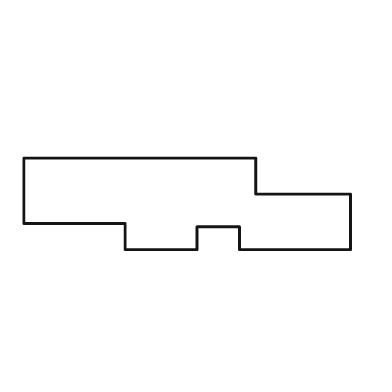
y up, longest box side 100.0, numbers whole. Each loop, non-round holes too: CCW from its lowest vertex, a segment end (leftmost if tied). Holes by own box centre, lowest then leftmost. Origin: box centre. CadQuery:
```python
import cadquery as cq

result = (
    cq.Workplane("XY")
    .moveTo(-19.0, -14.0)
    .lineTo(3.0, -14.0)
    .lineTo(3.0, -7.0)
    .lineTo(16.0, -7.0)
    .lineTo(16.0, -14.0)
    .lineTo(50.0, -14.0)
    .lineTo(50.0, 3.0)
    .lineTo(21.0, 3.0)
    .lineTo(21.0, 14.0)
    .lineTo(-50.0, 14.0)
    .lineTo(-50.0, -6.0)
    .lineTo(-19.0, -6.0)
    .close()
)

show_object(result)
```